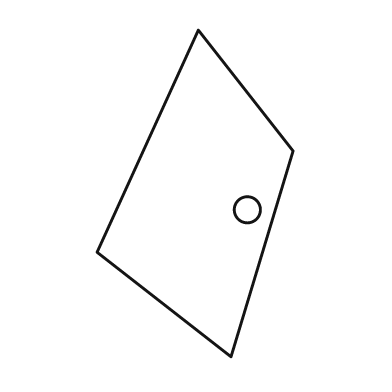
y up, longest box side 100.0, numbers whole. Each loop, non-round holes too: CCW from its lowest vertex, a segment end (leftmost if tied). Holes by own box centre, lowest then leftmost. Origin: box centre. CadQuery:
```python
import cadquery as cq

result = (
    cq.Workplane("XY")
    .moveTo(11.0, -50.0)
    .lineTo(30.0, 13.0)
    .lineTo(1.0, 50.0)
    .lineTo(-30.0, -18.0)
    .close()
    .moveTo(16.0, -5.0)
    .circle(4.0)
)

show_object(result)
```